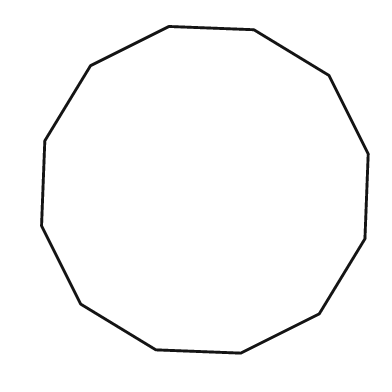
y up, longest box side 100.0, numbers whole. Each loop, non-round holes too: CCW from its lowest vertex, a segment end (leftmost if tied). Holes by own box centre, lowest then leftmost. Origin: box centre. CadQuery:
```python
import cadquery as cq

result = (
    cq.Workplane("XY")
    .moveTo(11.0, -50.0)
    .lineTo(35.0, -38.0)
    .lineTo(49.0, -15.0)
    .lineTo(50.0, 11.0)
    .lineTo(38.0, 35.0)
    .lineTo(15.0, 49.0)
    .lineTo(-11.0, 50.0)
    .lineTo(-35.0, 38.0)
    .lineTo(-49.0, 15.0)
    .lineTo(-50.0, -11.0)
    .lineTo(-38.0, -35.0)
    .lineTo(-15.0, -49.0)
    .close()
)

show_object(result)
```